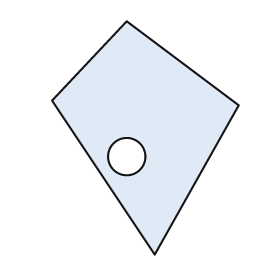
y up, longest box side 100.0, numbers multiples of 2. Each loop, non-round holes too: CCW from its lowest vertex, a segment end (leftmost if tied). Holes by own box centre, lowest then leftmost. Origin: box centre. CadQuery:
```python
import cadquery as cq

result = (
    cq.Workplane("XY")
    .moveTo(4.0, -50.0)
    .lineTo(40.0, 14.0)
    .lineTo(-8.0, 50.0)
    .lineTo(-40.0, 16.0)
    .close()
    .moveTo(-8.0, -8.0)
    .circle(8.0)
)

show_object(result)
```